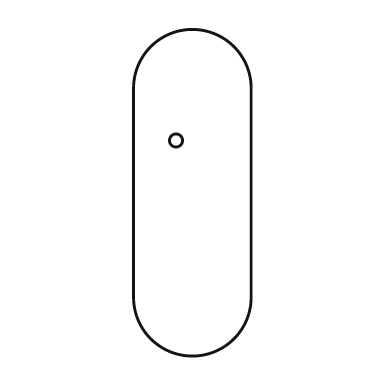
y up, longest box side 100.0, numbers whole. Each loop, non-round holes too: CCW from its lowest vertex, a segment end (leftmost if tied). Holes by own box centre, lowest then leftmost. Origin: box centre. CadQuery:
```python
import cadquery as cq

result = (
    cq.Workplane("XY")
    .moveTo(-18.0, -32.0)
    .threePointArc((0.0, -50.0), (18.0, -32.0))
    .lineTo(18.0, 32.0)
    .threePointArc((0.0, 50.0), (-18.0, 32.0))
    .close()
    .moveTo(-5.0, 16.0)
    .circle(2.0)
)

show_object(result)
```